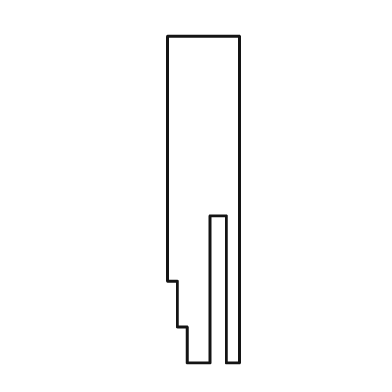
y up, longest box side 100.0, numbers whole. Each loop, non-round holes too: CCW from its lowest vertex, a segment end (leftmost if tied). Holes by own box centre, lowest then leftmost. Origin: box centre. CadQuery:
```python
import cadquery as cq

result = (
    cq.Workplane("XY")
    .moveTo(-5.0, -50.0)
    .lineTo(2.0, -50.0)
    .lineTo(2.0, -5.0)
    .lineTo(7.0, -5.0)
    .lineTo(7.0, -50.0)
    .lineTo(11.0, -50.0)
    .lineTo(11.0, 50.0)
    .lineTo(-11.0, 50.0)
    .lineTo(-11.0, -25.0)
    .lineTo(-8.0, -25.0)
    .lineTo(-8.0, -39.0)
    .lineTo(-5.0, -39.0)
    .close()
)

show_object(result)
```